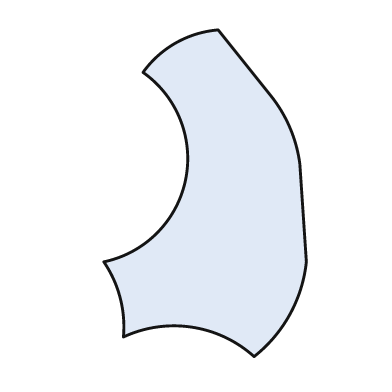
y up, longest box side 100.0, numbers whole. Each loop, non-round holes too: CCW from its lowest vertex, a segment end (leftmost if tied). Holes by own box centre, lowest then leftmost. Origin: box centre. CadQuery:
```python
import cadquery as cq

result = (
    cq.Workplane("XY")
    .moveTo(15.0, -50.0)
    .threePointArc((26.0, -37.0), (31.0, -21.0))
    .lineTo(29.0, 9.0)
    .threePointArc((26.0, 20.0), (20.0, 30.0))
    .lineTo(4.0, 50.0)
    .threePointArc((-9.0, 46.0), (-19.0, 37.0))
    .threePointArc((-6.0, 4.0), (-31.0, -21.0))
    .threePointArc((-26.0, -32.0), (-25.0, -44.0))
    .threePointArc((-4.0, -41.0), (15.0, -50.0))
    .close()
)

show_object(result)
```